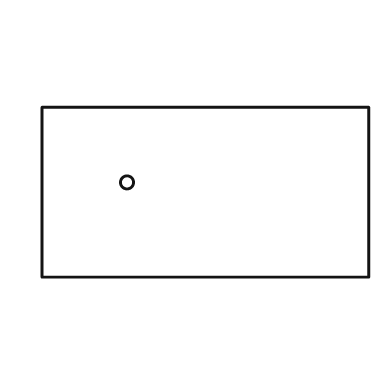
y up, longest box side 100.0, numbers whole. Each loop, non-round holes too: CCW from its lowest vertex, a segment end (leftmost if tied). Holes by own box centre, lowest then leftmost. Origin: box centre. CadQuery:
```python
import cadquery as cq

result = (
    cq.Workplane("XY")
    .moveTo(-50.0, -26.0)
    .lineTo(50.0, -26.0)
    .lineTo(50.0, 26.0)
    .lineTo(-50.0, 26.0)
    .close()
    .moveTo(-24.0, 3.0)
    .circle(2.0)
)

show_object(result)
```